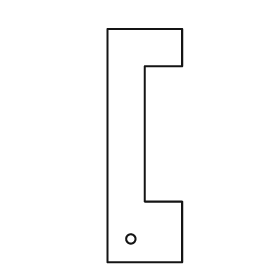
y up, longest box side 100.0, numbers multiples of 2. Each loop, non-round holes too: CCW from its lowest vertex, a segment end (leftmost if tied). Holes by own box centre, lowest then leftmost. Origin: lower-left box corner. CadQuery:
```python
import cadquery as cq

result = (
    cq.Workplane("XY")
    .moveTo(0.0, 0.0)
    .lineTo(32.0, 0.0)
    .lineTo(32.0, 26.0)
    .lineTo(16.0, 26.0)
    .lineTo(16.0, 84.0)
    .lineTo(32.0, 84.0)
    .lineTo(32.0, 100.0)
    .lineTo(0.0, 100.0)
    .close()
    .moveTo(10.0, 10.0)
    .circle(2.0)
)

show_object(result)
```